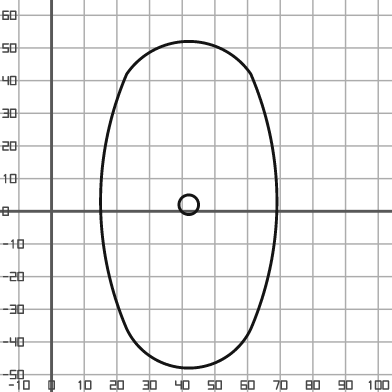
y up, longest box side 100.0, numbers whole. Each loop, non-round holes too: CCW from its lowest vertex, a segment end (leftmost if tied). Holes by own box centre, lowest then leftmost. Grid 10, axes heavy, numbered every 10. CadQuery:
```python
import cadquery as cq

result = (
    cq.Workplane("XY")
    .moveTo(23.0, -36.0)
    .threePointArc((42.0, -48.0), (61.0, -36.0))
    .threePointArc((69.0, 3.0), (61.0, 42.0))
    .threePointArc((42.0, 52.0), (23.0, 42.0))
    .threePointArc((15.0, 3.0), (23.0, -36.0))
    .close()
    .moveTo(42.0, 2.0)
    .circle(3.0)
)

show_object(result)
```